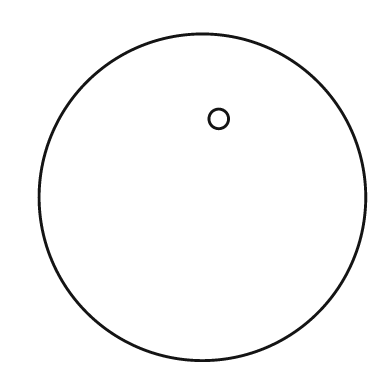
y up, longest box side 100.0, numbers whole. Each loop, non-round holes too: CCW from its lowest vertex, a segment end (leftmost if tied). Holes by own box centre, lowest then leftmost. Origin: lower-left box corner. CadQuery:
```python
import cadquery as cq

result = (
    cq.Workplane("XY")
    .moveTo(50.0, 50.0)
    .circle(50.0)
    .moveTo(55.0, 74.0)
    .circle(3.0)
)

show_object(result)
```